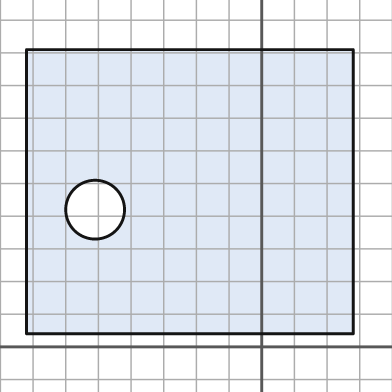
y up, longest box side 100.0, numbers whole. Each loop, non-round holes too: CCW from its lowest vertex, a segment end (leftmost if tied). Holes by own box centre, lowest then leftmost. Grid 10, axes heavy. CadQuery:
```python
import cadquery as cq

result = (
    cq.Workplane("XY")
    .moveTo(-72.0, 4.0)
    .lineTo(28.0, 4.0)
    .lineTo(28.0, 91.0)
    .lineTo(-72.0, 91.0)
    .close()
    .moveTo(-51.0, 42.0)
    .circle(9.0)
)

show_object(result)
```